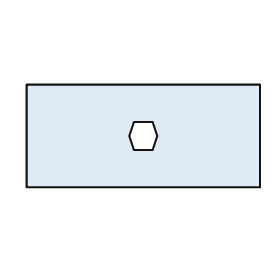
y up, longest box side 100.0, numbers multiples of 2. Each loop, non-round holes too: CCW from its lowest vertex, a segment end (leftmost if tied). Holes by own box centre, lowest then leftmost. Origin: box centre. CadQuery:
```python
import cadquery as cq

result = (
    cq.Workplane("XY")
    .moveTo(-50.0, -22.0)
    .lineTo(50.0, -22.0)
    .lineTo(50.0, 22.0)
    .lineTo(-50.0, 22.0)
    .close()
    .moveTo(-4.0, -6.0)
    .lineTo(4.0, -6.0)
    .lineTo(6.0, 0.0)
    .lineTo(4.0, 6.0)
    .lineTo(-4.0, 6.0)
    .lineTo(-6.0, 0.0)
    .close()
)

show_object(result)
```